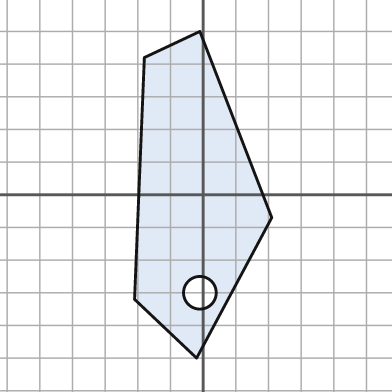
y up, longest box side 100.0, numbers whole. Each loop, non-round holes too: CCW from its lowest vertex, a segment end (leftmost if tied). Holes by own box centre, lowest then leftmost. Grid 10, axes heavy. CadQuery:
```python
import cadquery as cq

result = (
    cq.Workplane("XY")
    .moveTo(-2.0, -50.0)
    .lineTo(21.0, -7.0)
    .lineTo(-1.0, 50.0)
    .lineTo(-18.0, 42.0)
    .lineTo(-21.0, -32.0)
    .close()
    .moveTo(-1.0, -30.0)
    .circle(5.0)
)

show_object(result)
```